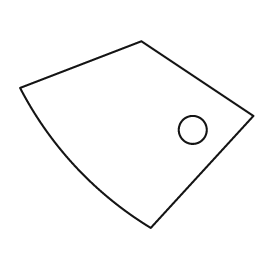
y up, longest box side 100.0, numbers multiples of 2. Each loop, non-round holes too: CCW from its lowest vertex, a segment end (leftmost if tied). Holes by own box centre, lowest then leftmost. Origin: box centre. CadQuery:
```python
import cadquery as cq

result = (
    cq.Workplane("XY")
    .moveTo(6.0, -40.0)
    .lineTo(50.0, 8.0)
    .lineTo(2.0, 40.0)
    .lineTo(-50.0, 20.0)
    .threePointArc((-26.0, -14.0), (6.0, -40.0))
    .close()
    .moveTo(24.0, 2.0)
    .circle(6.0)
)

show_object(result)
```